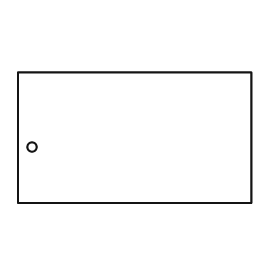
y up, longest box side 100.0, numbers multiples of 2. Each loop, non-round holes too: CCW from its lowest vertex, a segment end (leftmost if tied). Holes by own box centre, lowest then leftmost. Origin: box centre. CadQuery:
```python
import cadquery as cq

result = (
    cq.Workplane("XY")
    .moveTo(-50.0, -28.0)
    .lineTo(50.0, -28.0)
    .lineTo(50.0, 28.0)
    .lineTo(-50.0, 28.0)
    .close()
    .moveTo(-44.0, -4.0)
    .circle(2.0)
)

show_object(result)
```